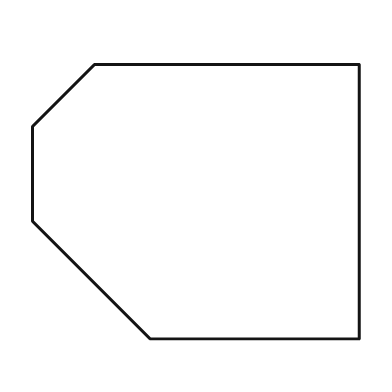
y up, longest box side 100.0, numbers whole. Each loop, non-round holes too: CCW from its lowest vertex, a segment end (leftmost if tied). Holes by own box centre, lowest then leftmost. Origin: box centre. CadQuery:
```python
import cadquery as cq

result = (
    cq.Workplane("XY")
    .moveTo(-14.0, -42.0)
    .lineTo(50.0, -42.0)
    .lineTo(50.0, 42.0)
    .lineTo(-31.0, 42.0)
    .lineTo(-50.0, 23.0)
    .lineTo(-50.0, -6.0)
    .close()
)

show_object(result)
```